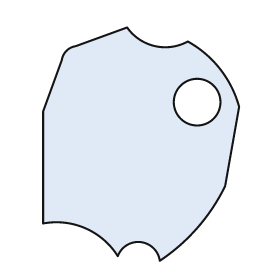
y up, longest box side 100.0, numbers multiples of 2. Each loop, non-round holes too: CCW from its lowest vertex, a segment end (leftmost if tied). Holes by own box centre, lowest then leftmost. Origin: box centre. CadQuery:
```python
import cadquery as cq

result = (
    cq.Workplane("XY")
    .moveTo(8.0, -50.0)
    .threePointArc((24.0, -36.0), (36.0, -18.0))
    .lineTo(42.0, 16.0)
    .threePointArc((34.0, 32.0), (20.0, 44.0))
    .threePointArc((6.0, 42.0), (-6.0, 50.0))
    .lineTo(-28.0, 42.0)
    .threePointArc((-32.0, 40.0), (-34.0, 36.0))
    .lineTo(-42.0, 14.0)
    .lineTo(-42.0, -34.0)
    .threePointArc((-24.0, -36.0), (-10.0, -48.0))
    .threePointArc((0.0, -42.0), (8.0, -50.0))
    .close()
    .moveTo(24.0, 18.0)
    .circle(10.0)
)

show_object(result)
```